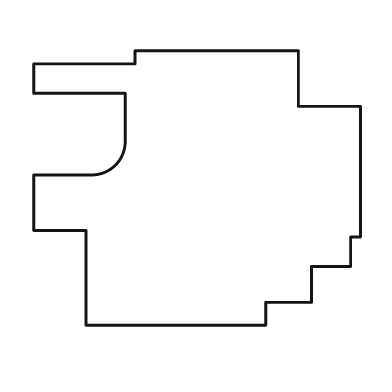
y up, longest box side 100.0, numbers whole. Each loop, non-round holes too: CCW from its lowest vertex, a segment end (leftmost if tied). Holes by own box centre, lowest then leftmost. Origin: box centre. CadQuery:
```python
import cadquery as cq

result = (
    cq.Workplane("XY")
    .moveTo(-34.0, -42.0)
    .lineTo(21.0, -42.0)
    .lineTo(21.0, -35.0)
    .lineTo(35.0, -35.0)
    .lineTo(35.0, -24.0)
    .lineTo(47.0, -24.0)
    .lineTo(47.0, -15.0)
    .lineTo(50.0, -15.0)
    .lineTo(50.0, 25.0)
    .lineTo(31.0, 25.0)
    .lineTo(31.0, 42.0)
    .lineTo(-19.0, 42.0)
    .lineTo(-19.0, 38.0)
    .lineTo(-50.0, 38.0)
    .lineTo(-50.0, 29.0)
    .lineTo(-22.0, 29.0)
    .lineTo(-22.0, 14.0)
    .threePointArc((-25.0, 7.0), (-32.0, 4.0))
    .lineTo(-50.0, 4.0)
    .lineTo(-50.0, -13.0)
    .lineTo(-34.0, -13.0)
    .close()
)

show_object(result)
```